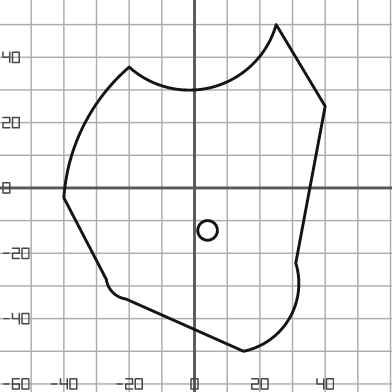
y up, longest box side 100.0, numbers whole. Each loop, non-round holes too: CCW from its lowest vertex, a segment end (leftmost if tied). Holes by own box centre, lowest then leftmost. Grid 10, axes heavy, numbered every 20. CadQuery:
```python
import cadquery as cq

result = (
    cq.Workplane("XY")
    .moveTo(15.0, -50.0)
    .threePointArc((29.0, -40.0), (31.0, -23.0))
    .lineTo(40.0, 25.0)
    .lineTo(25.0, 50.0)
    .threePointArc((6.0, 31.0), (-20.0, 37.0))
    .threePointArc((-34.0, 19.0), (-40.0, -3.0))
    .lineTo(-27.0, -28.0)
    .threePointArc((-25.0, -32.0), (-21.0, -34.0))
    .close()
    .moveTo(4.0, -13.0)
    .circle(3.0)
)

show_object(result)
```